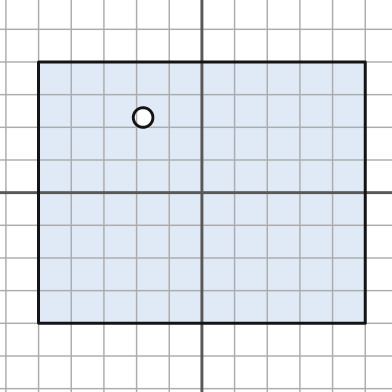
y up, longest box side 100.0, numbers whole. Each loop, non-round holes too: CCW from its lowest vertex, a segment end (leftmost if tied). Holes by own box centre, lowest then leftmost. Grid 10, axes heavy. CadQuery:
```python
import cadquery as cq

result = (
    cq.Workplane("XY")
    .moveTo(-50.0, -40.0)
    .lineTo(50.0, -40.0)
    .lineTo(50.0, 40.0)
    .lineTo(-50.0, 40.0)
    .close()
    .moveTo(-18.0, 23.0)
    .circle(3.0)
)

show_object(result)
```